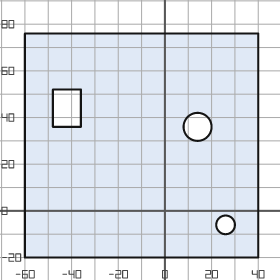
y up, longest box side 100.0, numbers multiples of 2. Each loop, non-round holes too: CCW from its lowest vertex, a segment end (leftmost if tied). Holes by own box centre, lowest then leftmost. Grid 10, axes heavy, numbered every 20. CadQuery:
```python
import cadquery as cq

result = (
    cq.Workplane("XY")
    .moveTo(-60.0, -20.0)
    .lineTo(40.0, -20.0)
    .lineTo(40.0, 76.0)
    .lineTo(-60.0, 76.0)
    .close()
    .moveTo(26.0, -6.0)
    .circle(4.0)
    .moveTo(14.0, 36.0)
    .circle(6.0)
    .moveTo(-48.0, 36.0)
    .lineTo(-36.0, 36.0)
    .lineTo(-36.0, 52.0)
    .lineTo(-48.0, 52.0)
    .close()
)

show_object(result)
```